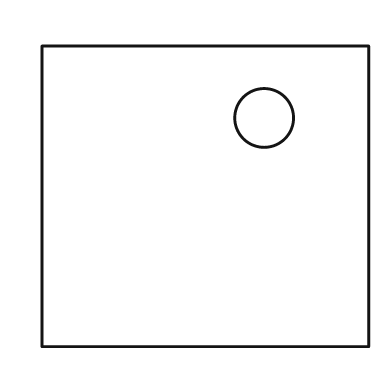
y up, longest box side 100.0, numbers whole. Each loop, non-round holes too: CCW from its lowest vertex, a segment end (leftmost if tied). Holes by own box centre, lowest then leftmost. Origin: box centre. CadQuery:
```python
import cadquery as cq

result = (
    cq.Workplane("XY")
    .moveTo(-50.0, -46.0)
    .lineTo(50.0, -46.0)
    .lineTo(50.0, 46.0)
    .lineTo(-50.0, 46.0)
    .close()
    .moveTo(18.0, 24.0)
    .circle(9.0)
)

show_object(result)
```